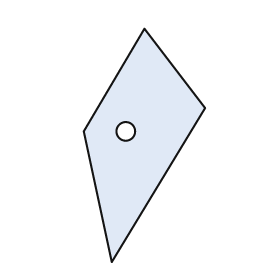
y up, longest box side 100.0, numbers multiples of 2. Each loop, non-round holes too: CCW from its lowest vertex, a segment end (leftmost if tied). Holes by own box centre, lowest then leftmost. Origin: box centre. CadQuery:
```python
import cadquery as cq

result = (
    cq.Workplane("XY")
    .moveTo(-14.0, -50.0)
    .lineTo(26.0, 16.0)
    .lineTo(0.0, 50.0)
    .lineTo(-26.0, 6.0)
    .close()
    .moveTo(-8.0, 6.0)
    .circle(4.0)
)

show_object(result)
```